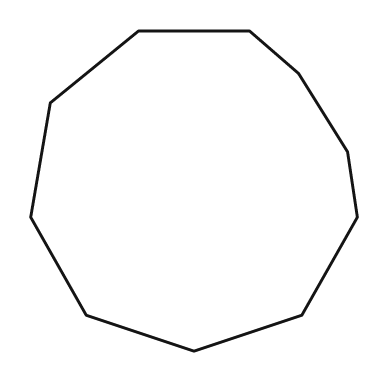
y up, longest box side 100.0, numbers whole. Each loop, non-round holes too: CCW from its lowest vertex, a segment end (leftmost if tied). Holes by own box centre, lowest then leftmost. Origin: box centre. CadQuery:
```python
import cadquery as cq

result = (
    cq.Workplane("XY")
    .moveTo(0.0, -49.0)
    .lineTo(33.0, -38.0)
    .lineTo(50.0, -8.0)
    .lineTo(47.0, 12.0)
    .lineTo(32.0, 36.0)
    .lineTo(17.0, 49.0)
    .lineTo(-17.0, 49.0)
    .lineTo(-44.0, 27.0)
    .lineTo(-50.0, -8.0)
    .lineTo(-33.0, -38.0)
    .close()
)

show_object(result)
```